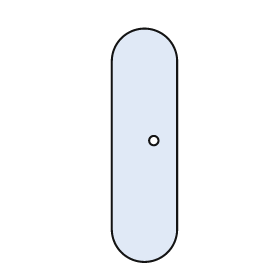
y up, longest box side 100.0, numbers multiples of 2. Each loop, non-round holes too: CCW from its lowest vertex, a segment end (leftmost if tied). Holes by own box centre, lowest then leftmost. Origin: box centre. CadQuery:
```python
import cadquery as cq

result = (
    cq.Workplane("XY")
    .moveTo(-14.0, -36.0)
    .threePointArc((0.0, -50.0), (14.0, -36.0))
    .lineTo(14.0, 36.0)
    .threePointArc((0.0, 50.0), (-14.0, 36.0))
    .close()
    .moveTo(4.0, 2.0)
    .circle(2.0)
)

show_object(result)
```